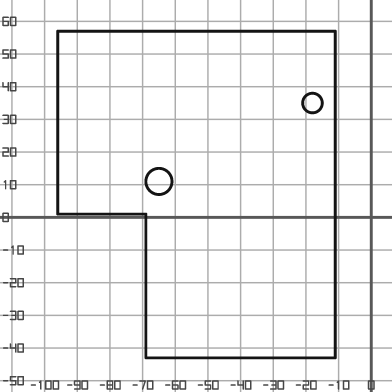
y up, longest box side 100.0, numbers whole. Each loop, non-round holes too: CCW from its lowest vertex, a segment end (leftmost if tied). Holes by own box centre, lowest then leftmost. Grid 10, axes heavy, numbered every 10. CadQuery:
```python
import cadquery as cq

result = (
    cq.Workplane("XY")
    .moveTo(-69.0, -43.0)
    .lineTo(-11.0, -43.0)
    .lineTo(-11.0, 57.0)
    .lineTo(-96.0, 57.0)
    .lineTo(-96.0, 1.0)
    .lineTo(-69.0, 1.0)
    .close()
    .moveTo(-65.0, 11.0)
    .circle(4.0)
    .moveTo(-18.0, 35.0)
    .circle(3.0)
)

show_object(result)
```